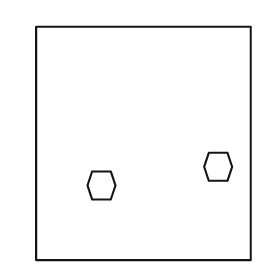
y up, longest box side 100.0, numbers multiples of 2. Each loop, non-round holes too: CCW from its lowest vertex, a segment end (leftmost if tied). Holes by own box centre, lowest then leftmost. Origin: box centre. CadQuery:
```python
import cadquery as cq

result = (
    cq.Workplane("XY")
    .moveTo(-46.0, -50.0)
    .lineTo(46.0, -50.0)
    .lineTo(46.0, 50.0)
    .lineTo(-46.0, 50.0)
    .close()
    .moveTo(-22.0, -24.0)
    .lineTo(-14.0, -24.0)
    .lineTo(-12.0, -18.0)
    .lineTo(-14.0, -12.0)
    .lineTo(-22.0, -12.0)
    .lineTo(-24.0, -18.0)
    .close()
    .moveTo(28.0, -16.0)
    .lineTo(36.0, -16.0)
    .lineTo(38.0, -10.0)
    .lineTo(36.0, -4.0)
    .lineTo(28.0, -4.0)
    .lineTo(26.0, -10.0)
    .close()
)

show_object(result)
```